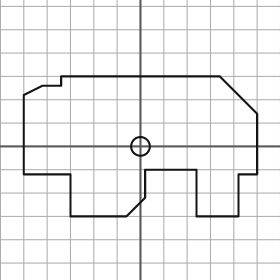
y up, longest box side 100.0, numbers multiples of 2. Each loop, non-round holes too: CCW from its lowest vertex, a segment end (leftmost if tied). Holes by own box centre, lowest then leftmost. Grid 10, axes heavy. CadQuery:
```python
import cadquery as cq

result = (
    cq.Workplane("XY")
    .moveTo(-30.0, -30.0)
    .lineTo(-6.0, -30.0)
    .lineTo(2.0, -22.0)
    .lineTo(2.0, -10.0)
    .lineTo(24.0, -10.0)
    .lineTo(24.0, -30.0)
    .lineTo(42.0, -30.0)
    .lineTo(42.0, -12.0)
    .lineTo(50.0, -12.0)
    .lineTo(50.0, 14.0)
    .lineTo(34.0, 30.0)
    .lineTo(-34.0, 30.0)
    .lineTo(-34.0, 26.0)
    .lineTo(-42.0, 26.0)
    .lineTo(-50.0, 22.0)
    .lineTo(-50.0, -12.0)
    .lineTo(-30.0, -12.0)
    .close()
    .moveTo(0.0, 0.0)
    .circle(4.0)
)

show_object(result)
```